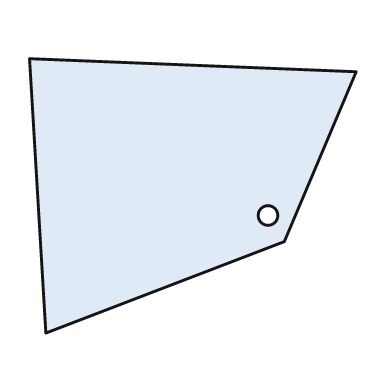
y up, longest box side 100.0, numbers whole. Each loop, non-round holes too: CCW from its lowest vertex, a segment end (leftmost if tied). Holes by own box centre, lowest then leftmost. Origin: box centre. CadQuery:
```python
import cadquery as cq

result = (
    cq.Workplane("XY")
    .moveTo(-45.0, -42.0)
    .lineTo(28.0, -14.0)
    .lineTo(50.0, 38.0)
    .lineTo(-50.0, 42.0)
    .close()
    .moveTo(23.0, -6.0)
    .circle(3.0)
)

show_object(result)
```